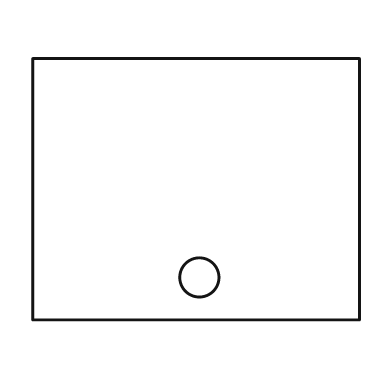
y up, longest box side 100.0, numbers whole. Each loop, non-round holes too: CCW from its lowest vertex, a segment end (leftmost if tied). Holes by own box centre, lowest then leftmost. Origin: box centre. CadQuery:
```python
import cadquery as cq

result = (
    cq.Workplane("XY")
    .moveTo(-50.0, -40.0)
    .lineTo(50.0, -40.0)
    .lineTo(50.0, 40.0)
    .lineTo(-50.0, 40.0)
    .close()
    .moveTo(1.0, -27.0)
    .circle(6.0)
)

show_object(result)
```